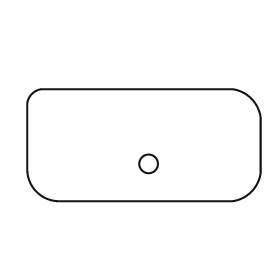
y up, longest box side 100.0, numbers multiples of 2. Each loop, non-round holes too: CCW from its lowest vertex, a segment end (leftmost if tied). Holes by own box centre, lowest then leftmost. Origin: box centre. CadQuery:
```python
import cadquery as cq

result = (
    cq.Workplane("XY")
    .moveTo(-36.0, -24.0)
    .lineTo(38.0, -24.0)
    .threePointArc((46.0, -20.0), (50.0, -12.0))
    .lineTo(50.0, 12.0)
    .threePointArc((46.0, 20.0), (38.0, 24.0))
    .lineTo(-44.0, 24.0)
    .threePointArc((-48.0, 22.0), (-50.0, 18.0))
    .lineTo(-50.0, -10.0)
    .threePointArc((-46.0, -20.0), (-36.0, -24.0))
    .close()
    .moveTo(2.0, -8.0)
    .circle(4.0)
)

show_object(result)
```